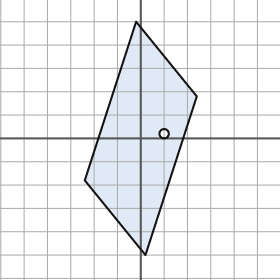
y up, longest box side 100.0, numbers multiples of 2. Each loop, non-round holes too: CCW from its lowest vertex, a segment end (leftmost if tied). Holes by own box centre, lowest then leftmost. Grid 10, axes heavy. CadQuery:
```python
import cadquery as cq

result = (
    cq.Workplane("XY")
    .moveTo(2.0, -50.0)
    .lineTo(24.0, 18.0)
    .lineTo(-2.0, 50.0)
    .lineTo(-24.0, -18.0)
    .close()
    .moveTo(10.0, 2.0)
    .circle(2.0)
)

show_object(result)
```